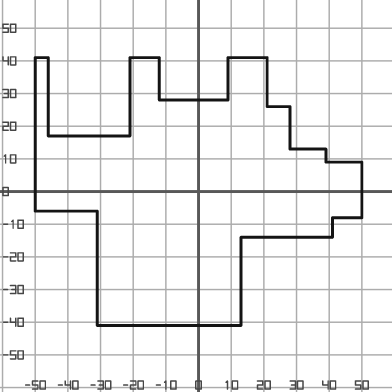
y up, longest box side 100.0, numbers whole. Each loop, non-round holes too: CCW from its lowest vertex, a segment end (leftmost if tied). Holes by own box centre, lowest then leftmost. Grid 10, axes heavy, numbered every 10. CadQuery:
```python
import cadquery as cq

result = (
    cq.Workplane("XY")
    .moveTo(-31.0, -41.0)
    .lineTo(13.0, -41.0)
    .lineTo(13.0, -14.0)
    .lineTo(41.0, -14.0)
    .lineTo(41.0, -8.0)
    .lineTo(50.0, -8.0)
    .lineTo(50.0, 9.0)
    .lineTo(39.0, 9.0)
    .lineTo(39.0, 13.0)
    .lineTo(28.0, 13.0)
    .lineTo(28.0, 26.0)
    .lineTo(21.0, 26.0)
    .lineTo(21.0, 41.0)
    .lineTo(9.0, 41.0)
    .lineTo(9.0, 28.0)
    .lineTo(-12.0, 28.0)
    .lineTo(-12.0, 41.0)
    .lineTo(-21.0, 41.0)
    .lineTo(-21.0, 17.0)
    .lineTo(-46.0, 17.0)
    .lineTo(-46.0, 41.0)
    .lineTo(-50.0, 41.0)
    .lineTo(-50.0, -6.0)
    .lineTo(-31.0, -6.0)
    .close()
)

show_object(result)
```